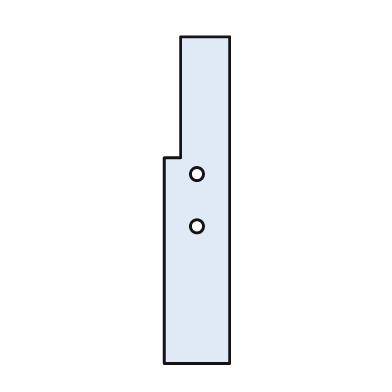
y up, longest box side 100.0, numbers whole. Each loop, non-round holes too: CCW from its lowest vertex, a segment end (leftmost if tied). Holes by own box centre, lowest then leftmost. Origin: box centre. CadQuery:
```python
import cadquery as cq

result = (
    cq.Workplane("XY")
    .moveTo(-10.0, -50.0)
    .lineTo(10.0, -50.0)
    .lineTo(10.0, 50.0)
    .lineTo(-5.0, 50.0)
    .lineTo(-5.0, 13.0)
    .lineTo(-10.0, 13.0)
    .close()
    .moveTo(0.0, -8.0)
    .circle(2.0)
    .moveTo(0.0, 8.0)
    .circle(2.0)
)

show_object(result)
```